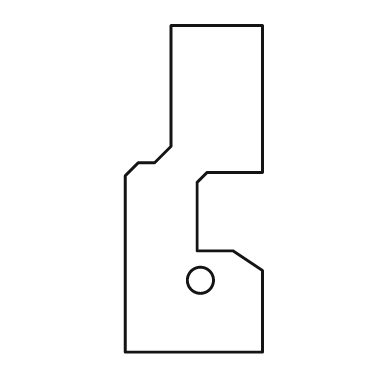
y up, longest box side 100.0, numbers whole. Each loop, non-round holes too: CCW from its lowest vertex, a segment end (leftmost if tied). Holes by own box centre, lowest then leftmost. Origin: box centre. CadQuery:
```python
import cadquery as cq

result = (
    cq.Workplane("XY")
    .moveTo(-21.0, -50.0)
    .lineTo(21.0, -50.0)
    .lineTo(21.0, -25.0)
    .lineTo(12.0, -19.0)
    .lineTo(1.0, -19.0)
    .lineTo(1.0, 2.0)
    .lineTo(4.0, 5.0)
    .lineTo(21.0, 5.0)
    .lineTo(21.0, 50.0)
    .lineTo(-7.0, 50.0)
    .lineTo(-7.0, 13.0)
    .lineTo(-12.0, 8.0)
    .lineTo(-17.0, 8.0)
    .lineTo(-21.0, 4.0)
    .close()
    .moveTo(2.0, -28.0)
    .circle(4.0)
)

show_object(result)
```